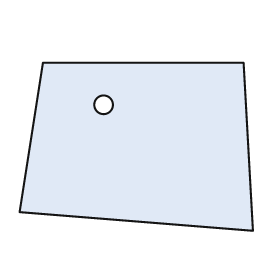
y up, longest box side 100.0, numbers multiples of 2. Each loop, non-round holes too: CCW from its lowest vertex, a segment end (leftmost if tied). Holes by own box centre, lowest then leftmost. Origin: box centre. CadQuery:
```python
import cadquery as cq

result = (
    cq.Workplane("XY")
    .moveTo(50.0, -36.0)
    .lineTo(46.0, 36.0)
    .lineTo(-40.0, 36.0)
    .lineTo(-50.0, -28.0)
    .close()
    .moveTo(-14.0, 18.0)
    .circle(4.0)
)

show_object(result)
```